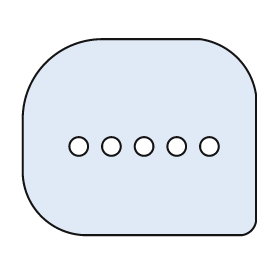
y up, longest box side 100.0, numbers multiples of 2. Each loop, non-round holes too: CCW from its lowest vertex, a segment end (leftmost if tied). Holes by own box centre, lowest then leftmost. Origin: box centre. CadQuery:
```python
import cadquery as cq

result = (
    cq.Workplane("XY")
    .moveTo(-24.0, -42.0)
    .lineTo(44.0, -42.0)
    .threePointArc((48.0, -40.0), (50.0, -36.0))
    .lineTo(50.0, 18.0)
    .threePointArc((42.0, 34.0), (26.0, 42.0))
    .lineTo(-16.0, 42.0)
    .threePointArc((-40.0, 32.0), (-50.0, 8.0))
    .lineTo(-50.0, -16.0)
    .threePointArc((-42.0, -34.0), (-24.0, -42.0))
    .close()
    .moveTo(-26.0, -4.0)
    .circle(4.0)
    .moveTo(-12.0, -4.0)
    .circle(4.0)
    .moveTo(2.0, -4.0)
    .circle(4.0)
    .moveTo(16.0, -4.0)
    .circle(4.0)
    .moveTo(30.0, -4.0)
    .circle(4.0)
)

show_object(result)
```